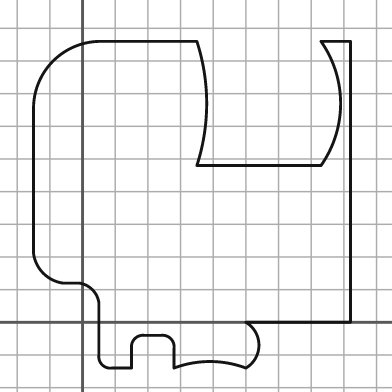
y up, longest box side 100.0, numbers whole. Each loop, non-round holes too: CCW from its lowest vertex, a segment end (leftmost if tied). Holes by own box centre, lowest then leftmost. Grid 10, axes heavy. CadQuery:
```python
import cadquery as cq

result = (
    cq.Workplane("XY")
    .moveTo(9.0, -14.0)
    .lineTo(15.0, -14.0)
    .lineTo(15.0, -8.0)
    .threePointArc((16.0, -5.0), (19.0, -4.0))
    .lineTo(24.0, -4.0)
    .threePointArc((27.0, -5.0), (28.0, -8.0))
    .lineTo(28.0, -14.0)
    .threePointArc((39.0, -12.0), (50.0, -14.0))
    .threePointArc((54.0, -7.0), (50.0, 0.0))
    .lineTo(82.0, 0.0)
    .lineTo(82.0, 86.0)
    .lineTo(73.0, 86.0)
    .threePointArc((79.0, 67.0), (73.0, 48.0))
    .lineTo(35.0, 48.0)
    .threePointArc((38.0, 67.0), (35.0, 86.0))
    .lineTo(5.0, 86.0)
    .threePointArc((-9.0, 80.0), (-15.0, 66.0))
    .lineTo(-15.0, 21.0)
    .threePointArc((-12.0, 15.0), (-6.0, 12.0))
    .lineTo(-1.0, 12.0)
    .threePointArc((3.0, 10.0), (5.0, 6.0))
    .lineTo(5.0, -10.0)
    .threePointArc((6.0, -13.0), (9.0, -14.0))
    .close()
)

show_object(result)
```